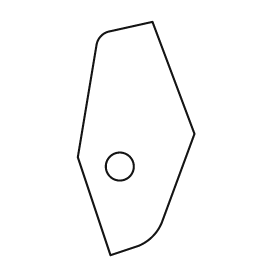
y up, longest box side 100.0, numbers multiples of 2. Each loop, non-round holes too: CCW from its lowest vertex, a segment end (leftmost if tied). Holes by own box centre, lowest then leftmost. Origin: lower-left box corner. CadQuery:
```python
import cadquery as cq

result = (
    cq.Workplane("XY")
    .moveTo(14.0, 0.0)
    .lineTo(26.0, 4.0)
    .threePointArc((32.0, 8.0), (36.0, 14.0))
    .lineTo(50.0, 52.0)
    .lineTo(32.0, 100.0)
    .lineTo(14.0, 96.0)
    .threePointArc((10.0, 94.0), (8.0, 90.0))
    .lineTo(0.0, 42.0)
    .close()
    .moveTo(18.0, 38.0)
    .circle(6.0)
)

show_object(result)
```